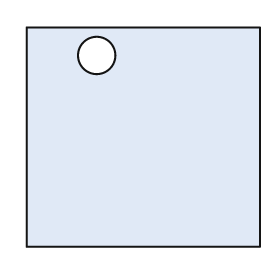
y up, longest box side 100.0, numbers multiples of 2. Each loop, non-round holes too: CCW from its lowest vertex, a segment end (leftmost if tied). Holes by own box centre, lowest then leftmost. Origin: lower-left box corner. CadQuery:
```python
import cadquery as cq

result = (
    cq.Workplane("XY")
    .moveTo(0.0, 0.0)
    .lineTo(100.0, 0.0)
    .lineTo(100.0, 94.0)
    .lineTo(0.0, 94.0)
    .close()
    .moveTo(30.0, 82.0)
    .circle(8.0)
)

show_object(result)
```